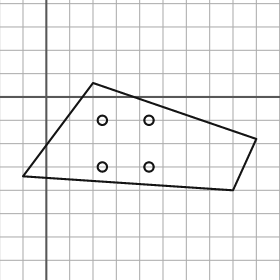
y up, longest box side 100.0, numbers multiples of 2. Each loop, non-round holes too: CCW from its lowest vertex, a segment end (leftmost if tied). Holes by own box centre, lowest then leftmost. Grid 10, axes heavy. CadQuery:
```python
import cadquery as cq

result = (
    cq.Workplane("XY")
    .moveTo(80.0, -40.0)
    .lineTo(90.0, -18.0)
    .lineTo(20.0, 6.0)
    .lineTo(-10.0, -34.0)
    .close()
    .moveTo(24.0, -30.0)
    .circle(2.0)
    .moveTo(44.0, -30.0)
    .circle(2.0)
    .moveTo(24.0, -10.0)
    .circle(2.0)
    .moveTo(44.0, -10.0)
    .circle(2.0)
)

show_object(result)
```